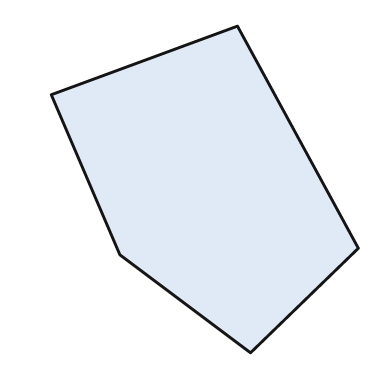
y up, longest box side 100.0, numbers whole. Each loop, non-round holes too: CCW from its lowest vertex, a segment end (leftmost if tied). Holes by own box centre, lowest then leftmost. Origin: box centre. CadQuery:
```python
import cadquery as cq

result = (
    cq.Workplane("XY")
    .moveTo(14.0, -50.0)
    .lineTo(47.0, -18.0)
    .lineTo(10.0, 50.0)
    .lineTo(-47.0, 29.0)
    .lineTo(-26.0, -20.0)
    .close()
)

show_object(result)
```